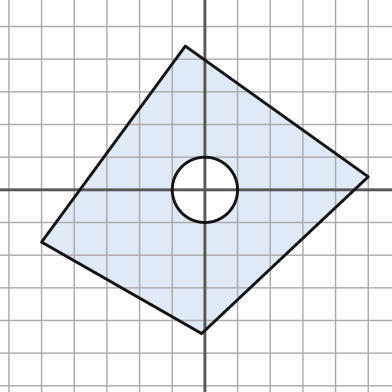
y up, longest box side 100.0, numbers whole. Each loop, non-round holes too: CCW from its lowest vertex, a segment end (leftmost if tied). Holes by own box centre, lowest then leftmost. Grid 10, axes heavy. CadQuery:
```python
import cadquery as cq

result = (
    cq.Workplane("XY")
    .moveTo(-1.0, -44.0)
    .lineTo(50.0, 4.0)
    .lineTo(-6.0, 44.0)
    .lineTo(-50.0, -16.0)
    .close()
    .moveTo(0.0, 0.0)
    .circle(10.0)
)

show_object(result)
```